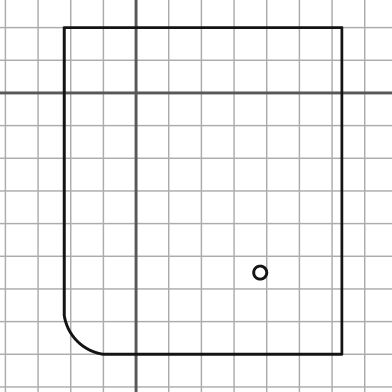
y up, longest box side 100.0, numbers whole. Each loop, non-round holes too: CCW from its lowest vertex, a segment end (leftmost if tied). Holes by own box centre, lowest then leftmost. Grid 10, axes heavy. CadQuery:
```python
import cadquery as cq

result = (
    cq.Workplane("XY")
    .moveTo(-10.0, -80.0)
    .lineTo(63.0, -80.0)
    .lineTo(63.0, 20.0)
    .lineTo(-22.0, 20.0)
    .lineTo(-22.0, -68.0)
    .threePointArc((-18.0, -76.0), (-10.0, -80.0))
    .close()
    .moveTo(38.0, -55.0)
    .circle(2.0)
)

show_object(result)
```